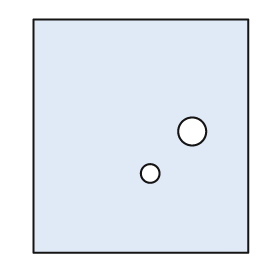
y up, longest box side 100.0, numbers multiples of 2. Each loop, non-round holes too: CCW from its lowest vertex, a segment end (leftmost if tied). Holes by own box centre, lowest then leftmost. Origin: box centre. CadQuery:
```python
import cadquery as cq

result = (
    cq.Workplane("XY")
    .moveTo(-46.0, -50.0)
    .lineTo(46.0, -50.0)
    .lineTo(46.0, 50.0)
    .lineTo(-46.0, 50.0)
    .close()
    .moveTo(4.0, -16.0)
    .circle(4.0)
    .moveTo(22.0, 2.0)
    .circle(6.0)
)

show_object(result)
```